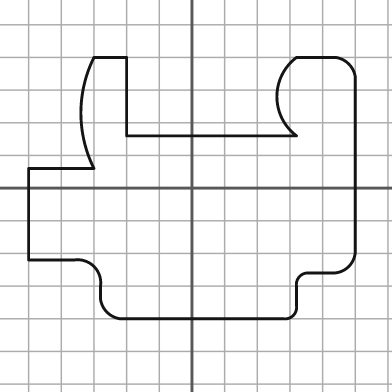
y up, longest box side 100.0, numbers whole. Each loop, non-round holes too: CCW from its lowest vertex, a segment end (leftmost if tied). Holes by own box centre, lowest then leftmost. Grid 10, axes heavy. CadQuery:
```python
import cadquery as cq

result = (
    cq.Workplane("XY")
    .moveTo(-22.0, -40.0)
    .lineTo(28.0, -40.0)
    .threePointArc((31.0, -39.0), (32.0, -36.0))
    .lineTo(32.0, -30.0)
    .threePointArc((33.0, -27.0), (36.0, -26.0))
    .lineTo(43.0, -26.0)
    .threePointArc((48.0, -24.0), (50.0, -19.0))
    .lineTo(50.0, 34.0)
    .threePointArc((48.0, 38.0), (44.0, 40.0))
    .lineTo(32.0, 40.0)
    .threePointArc((26.0, 28.0), (32.0, 16.0))
    .lineTo(-20.0, 16.0)
    .lineTo(-20.0, 40.0)
    .lineTo(-30.0, 40.0)
    .threePointArc((-34.0, 23.0), (-30.0, 6.0))
    .lineTo(-50.0, 6.0)
    .lineTo(-50.0, -22.0)
    .lineTo(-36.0, -22.0)
    .threePointArc((-30.0, -24.0), (-28.0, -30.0))
    .lineTo(-28.0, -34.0)
    .threePointArc((-26.0, -38.0), (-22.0, -40.0))
    .close()
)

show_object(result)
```